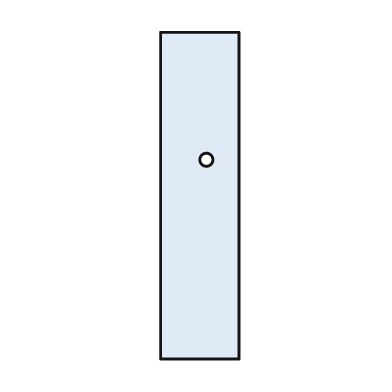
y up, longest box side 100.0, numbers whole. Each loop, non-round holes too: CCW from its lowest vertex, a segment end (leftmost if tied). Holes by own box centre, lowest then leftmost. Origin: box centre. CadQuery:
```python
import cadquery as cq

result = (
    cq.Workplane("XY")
    .moveTo(-12.0, -50.0)
    .lineTo(12.0, -50.0)
    .lineTo(12.0, 50.0)
    .lineTo(-12.0, 50.0)
    .close()
    .moveTo(2.0, 11.0)
    .circle(2.0)
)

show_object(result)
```